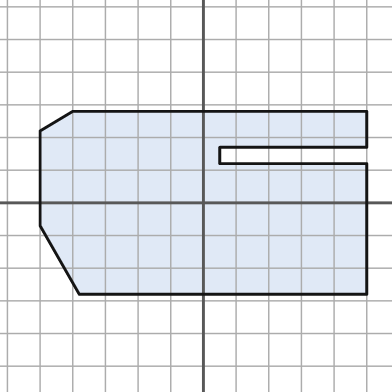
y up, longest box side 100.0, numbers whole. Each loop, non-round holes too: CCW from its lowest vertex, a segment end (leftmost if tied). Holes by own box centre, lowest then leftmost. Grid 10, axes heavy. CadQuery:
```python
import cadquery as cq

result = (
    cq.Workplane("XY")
    .moveTo(-38.0, -28.0)
    .lineTo(50.0, -28.0)
    .lineTo(50.0, 12.0)
    .lineTo(5.0, 12.0)
    .lineTo(5.0, 17.0)
    .lineTo(50.0, 17.0)
    .lineTo(50.0, 28.0)
    .lineTo(-40.0, 28.0)
    .lineTo(-50.0, 22.0)
    .lineTo(-50.0, -7.0)
    .close()
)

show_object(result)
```